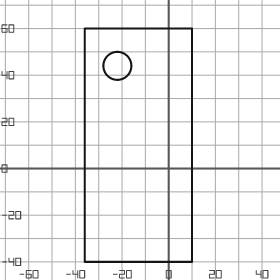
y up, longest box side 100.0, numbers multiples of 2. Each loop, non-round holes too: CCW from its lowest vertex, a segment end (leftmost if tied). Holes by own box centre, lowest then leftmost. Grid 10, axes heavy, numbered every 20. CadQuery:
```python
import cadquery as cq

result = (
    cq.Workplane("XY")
    .moveTo(-36.0, -40.0)
    .lineTo(10.0, -40.0)
    .lineTo(10.0, 60.0)
    .lineTo(-36.0, 60.0)
    .close()
    .moveTo(-22.0, 44.0)
    .circle(6.0)
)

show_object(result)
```